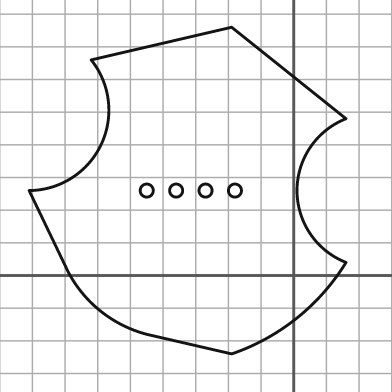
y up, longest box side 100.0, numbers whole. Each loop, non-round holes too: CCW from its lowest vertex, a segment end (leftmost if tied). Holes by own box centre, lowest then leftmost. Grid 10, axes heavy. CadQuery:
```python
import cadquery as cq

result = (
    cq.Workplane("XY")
    .moveTo(-19.0, -24.0)
    .threePointArc((1.0, -13.0), (16.0, 4.0))
    .threePointArc((1.0, 26.0), (16.0, 48.0))
    .lineTo(-19.0, 76.0)
    .lineTo(-62.0, 66.0)
    .threePointArc((-59.0, 40.0), (-81.0, 26.0))
    .lineTo(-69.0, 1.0)
    .threePointArc((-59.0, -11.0), (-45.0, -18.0))
    .close()
    .moveTo(-45.0, 26.0)
    .circle(2.0)
    .moveTo(-36.0, 26.0)
    .circle(2.0)
    .moveTo(-27.0, 26.0)
    .circle(2.0)
    .moveTo(-18.0, 26.0)
    .circle(2.0)
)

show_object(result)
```